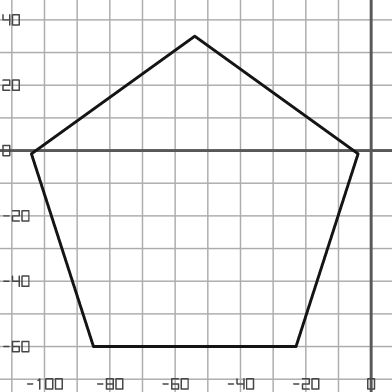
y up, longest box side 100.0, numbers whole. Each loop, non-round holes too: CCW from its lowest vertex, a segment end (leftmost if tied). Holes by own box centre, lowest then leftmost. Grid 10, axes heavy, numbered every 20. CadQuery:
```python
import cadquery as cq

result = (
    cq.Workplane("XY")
    .moveTo(-85.0, -60.0)
    .lineTo(-23.0, -60.0)
    .lineTo(-4.0, -1.0)
    .lineTo(-54.0, 35.0)
    .lineTo(-104.0, -1.0)
    .close()
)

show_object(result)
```